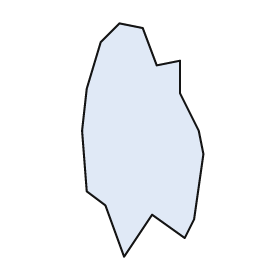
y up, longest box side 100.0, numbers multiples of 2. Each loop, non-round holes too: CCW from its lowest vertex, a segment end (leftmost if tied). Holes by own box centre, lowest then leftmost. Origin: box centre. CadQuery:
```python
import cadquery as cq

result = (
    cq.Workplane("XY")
    .moveTo(-8.0, -50.0)
    .lineTo(4.0, -32.0)
    .lineTo(18.0, -42.0)
    .lineTo(22.0, -34.0)
    .lineTo(26.0, -6.0)
    .lineTo(24.0, 4.0)
    .lineTo(16.0, 20.0)
    .lineTo(16.0, 34.0)
    .lineTo(6.0, 32.0)
    .lineTo(0.0, 48.0)
    .lineTo(-10.0, 50.0)
    .lineTo(-18.0, 42.0)
    .lineTo(-24.0, 22.0)
    .lineTo(-26.0, 4.0)
    .lineTo(-24.0, -22.0)
    .lineTo(-16.0, -28.0)
    .close()
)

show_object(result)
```